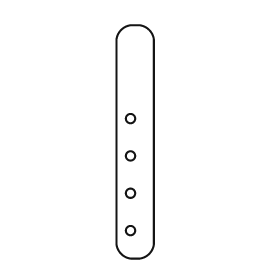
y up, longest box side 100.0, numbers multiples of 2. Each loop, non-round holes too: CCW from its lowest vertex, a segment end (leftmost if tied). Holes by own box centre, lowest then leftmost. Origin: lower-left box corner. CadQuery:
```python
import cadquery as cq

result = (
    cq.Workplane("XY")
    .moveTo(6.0, 0.0)
    .lineTo(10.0, 0.0)
    .threePointArc((14.0, 2.0), (16.0, 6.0))
    .lineTo(16.0, 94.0)
    .threePointArc((14.0, 98.0), (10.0, 100.0))
    .lineTo(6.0, 100.0)
    .threePointArc((2.0, 98.0), (0.0, 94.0))
    .lineTo(0.0, 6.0)
    .threePointArc((2.0, 2.0), (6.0, 0.0))
    .close()
    .moveTo(6.0, 12.0)
    .circle(2.0)
    .moveTo(6.0, 28.0)
    .circle(2.0)
    .moveTo(6.0, 44.0)
    .circle(2.0)
    .moveTo(6.0, 60.0)
    .circle(2.0)
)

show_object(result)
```